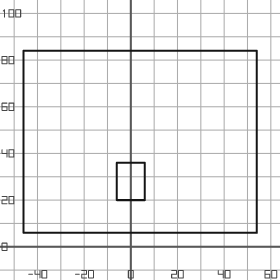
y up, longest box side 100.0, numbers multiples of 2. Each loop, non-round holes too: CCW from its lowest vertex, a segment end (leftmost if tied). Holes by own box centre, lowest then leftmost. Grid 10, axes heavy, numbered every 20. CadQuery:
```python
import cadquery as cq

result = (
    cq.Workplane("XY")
    .moveTo(-46.0, 6.0)
    .lineTo(54.0, 6.0)
    .lineTo(54.0, 84.0)
    .lineTo(-46.0, 84.0)
    .close()
    .moveTo(-6.0, 20.0)
    .lineTo(6.0, 20.0)
    .lineTo(6.0, 36.0)
    .lineTo(-6.0, 36.0)
    .close()
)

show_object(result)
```